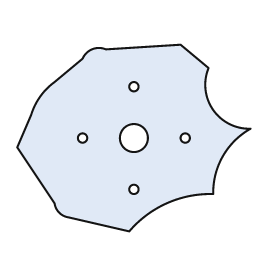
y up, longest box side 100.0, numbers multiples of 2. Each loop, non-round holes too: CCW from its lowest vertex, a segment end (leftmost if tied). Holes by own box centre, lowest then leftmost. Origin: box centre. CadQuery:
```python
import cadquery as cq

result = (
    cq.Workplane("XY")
    .moveTo(-2.0, -40.0)
    .threePointArc((14.0, -28.0), (34.0, -24.0))
    .threePointArc((38.0, -8.0), (50.0, 4.0))
    .threePointArc((34.0, 12.0), (32.0, 30.0))
    .lineTo(20.0, 40.0)
    .lineTo(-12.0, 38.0)
    .threePointArc((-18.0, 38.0), (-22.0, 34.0))
    .lineTo(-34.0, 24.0)
    .threePointArc((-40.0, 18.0), (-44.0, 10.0))
    .lineTo(-50.0, -4.0)
    .lineTo(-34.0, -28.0)
    .threePointArc((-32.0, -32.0), (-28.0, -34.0))
    .close()
    .moveTo(0.0, -22.0)
    .circle(2.0)
    .moveTo(-22.0, 0.0)
    .circle(2.0)
    .moveTo(0.0, 0.0)
    .circle(6.0)
    .moveTo(22.0, 0.0)
    .circle(2.0)
    .moveTo(0.0, 22.0)
    .circle(2.0)
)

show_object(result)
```